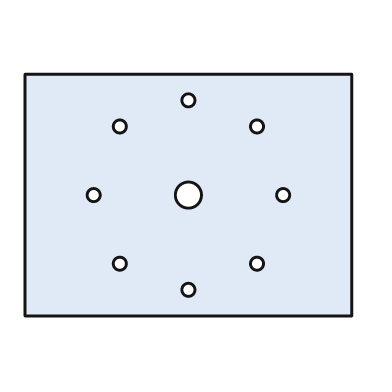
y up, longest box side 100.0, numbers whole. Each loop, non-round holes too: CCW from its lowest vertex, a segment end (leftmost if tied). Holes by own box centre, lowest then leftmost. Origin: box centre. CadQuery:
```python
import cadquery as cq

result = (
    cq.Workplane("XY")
    .moveTo(-50.0, -37.0)
    .lineTo(50.0, -37.0)
    .lineTo(50.0, 37.0)
    .lineTo(-50.0, 37.0)
    .close()
    .moveTo(0.0, -29.0)
    .circle(2.0)
    .moveTo(-21.0, -21.0)
    .circle(2.0)
    .moveTo(21.0, -21.0)
    .circle(2.0)
    .moveTo(-29.0, 0.0)
    .circle(2.0)
    .moveTo(0.0, 0.0)
    .circle(4.0)
    .moveTo(29.0, 0.0)
    .circle(2.0)
    .moveTo(-21.0, 21.0)
    .circle(2.0)
    .moveTo(21.0, 21.0)
    .circle(2.0)
    .moveTo(0.0, 29.0)
    .circle(2.0)
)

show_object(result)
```